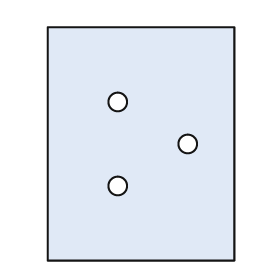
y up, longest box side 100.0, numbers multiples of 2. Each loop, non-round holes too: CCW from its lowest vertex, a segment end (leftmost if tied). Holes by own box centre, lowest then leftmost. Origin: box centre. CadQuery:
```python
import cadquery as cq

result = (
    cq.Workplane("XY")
    .moveTo(-40.0, -50.0)
    .lineTo(40.0, -50.0)
    .lineTo(40.0, 50.0)
    .lineTo(-40.0, 50.0)
    .close()
    .moveTo(-10.0, -18.0)
    .circle(4.0)
    .moveTo(20.0, 0.0)
    .circle(4.0)
    .moveTo(-10.0, 18.0)
    .circle(4.0)
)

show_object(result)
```